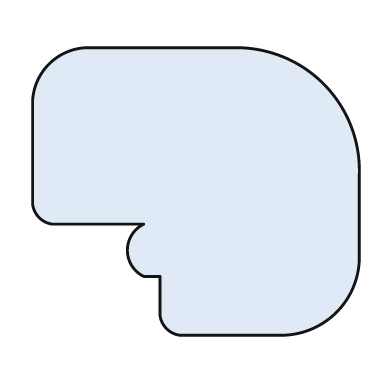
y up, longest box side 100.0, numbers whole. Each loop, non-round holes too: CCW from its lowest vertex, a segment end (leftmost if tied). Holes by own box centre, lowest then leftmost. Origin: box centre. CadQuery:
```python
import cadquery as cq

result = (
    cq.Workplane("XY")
    .moveTo(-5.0, -44.0)
    .lineTo(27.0, -44.0)
    .threePointArc((43.0, -37.0), (50.0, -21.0))
    .lineTo(50.0, 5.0)
    .threePointArc((39.0, 33.0), (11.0, 44.0))
    .lineTo(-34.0, 44.0)
    .threePointArc((-45.0, 39.0), (-50.0, 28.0))
    .lineTo(-50.0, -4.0)
    .threePointArc((-48.0, -8.0), (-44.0, -10.0))
    .lineTo(-16.0, -10.0)
    .threePointArc((-21.0, -18.0), (-16.0, -26.0))
    .lineTo(-11.0, -26.0)
    .lineTo(-11.0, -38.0)
    .threePointArc((-9.0, -42.0), (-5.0, -44.0))
    .close()
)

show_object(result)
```